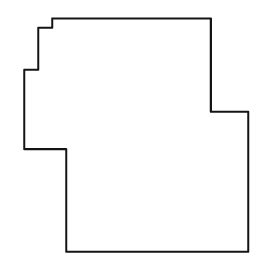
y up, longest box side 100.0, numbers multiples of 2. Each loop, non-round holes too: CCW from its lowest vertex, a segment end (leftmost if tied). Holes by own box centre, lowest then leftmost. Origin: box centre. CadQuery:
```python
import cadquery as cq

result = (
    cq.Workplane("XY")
    .moveTo(-30.0, -50.0)
    .lineTo(48.0, -50.0)
    .lineTo(48.0, 10.0)
    .lineTo(32.0, 10.0)
    .lineTo(32.0, 50.0)
    .lineTo(-36.0, 50.0)
    .lineTo(-36.0, 46.0)
    .lineTo(-42.0, 46.0)
    .lineTo(-42.0, 28.0)
    .lineTo(-48.0, 28.0)
    .lineTo(-48.0, -6.0)
    .lineTo(-30.0, -6.0)
    .close()
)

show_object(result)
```